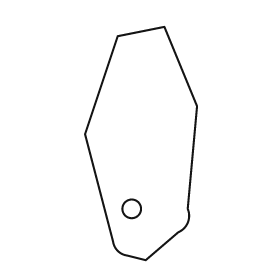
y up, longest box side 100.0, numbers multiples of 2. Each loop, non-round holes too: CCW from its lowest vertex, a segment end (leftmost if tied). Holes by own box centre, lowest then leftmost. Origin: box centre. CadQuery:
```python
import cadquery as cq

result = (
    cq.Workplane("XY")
    .moveTo(2.0, -50.0)
    .lineTo(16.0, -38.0)
    .threePointArc((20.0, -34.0), (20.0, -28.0))
    .lineTo(24.0, 16.0)
    .lineTo(10.0, 50.0)
    .lineTo(-10.0, 46.0)
    .lineTo(-24.0, 4.0)
    .lineTo(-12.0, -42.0)
    .threePointArc((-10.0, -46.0), (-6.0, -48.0))
    .close()
    .moveTo(-4.0, -28.0)
    .circle(4.0)
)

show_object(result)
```